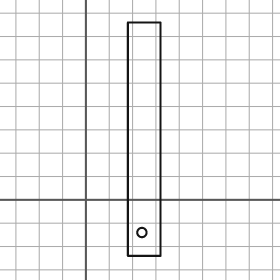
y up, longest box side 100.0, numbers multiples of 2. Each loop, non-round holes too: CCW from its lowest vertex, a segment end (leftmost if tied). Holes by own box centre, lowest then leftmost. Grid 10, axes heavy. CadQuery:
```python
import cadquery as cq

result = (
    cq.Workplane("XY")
    .moveTo(18.0, -24.0)
    .lineTo(32.0, -24.0)
    .lineTo(32.0, 76.0)
    .lineTo(18.0, 76.0)
    .close()
    .moveTo(24.0, -14.0)
    .circle(2.0)
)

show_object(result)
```